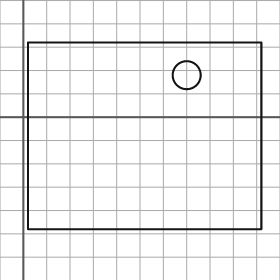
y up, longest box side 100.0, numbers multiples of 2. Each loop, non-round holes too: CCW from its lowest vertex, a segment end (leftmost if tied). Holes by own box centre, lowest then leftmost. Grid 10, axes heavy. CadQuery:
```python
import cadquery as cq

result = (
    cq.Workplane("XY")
    .moveTo(2.0, -48.0)
    .lineTo(102.0, -48.0)
    .lineTo(102.0, 32.0)
    .lineTo(2.0, 32.0)
    .close()
    .moveTo(70.0, 18.0)
    .circle(6.0)
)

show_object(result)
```